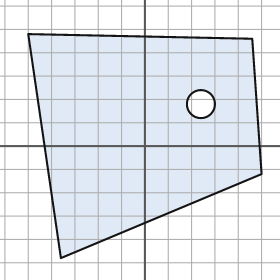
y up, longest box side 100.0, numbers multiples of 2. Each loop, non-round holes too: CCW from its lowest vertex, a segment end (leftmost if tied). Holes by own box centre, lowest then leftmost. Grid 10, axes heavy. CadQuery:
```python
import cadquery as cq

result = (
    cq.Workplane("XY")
    .moveTo(-36.0, -48.0)
    .lineTo(50.0, -12.0)
    .lineTo(46.0, 46.0)
    .lineTo(-50.0, 48.0)
    .close()
    .moveTo(24.0, 18.0)
    .circle(6.0)
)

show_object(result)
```